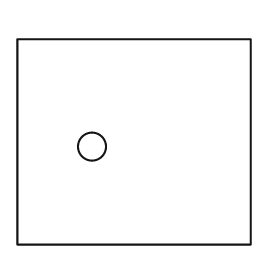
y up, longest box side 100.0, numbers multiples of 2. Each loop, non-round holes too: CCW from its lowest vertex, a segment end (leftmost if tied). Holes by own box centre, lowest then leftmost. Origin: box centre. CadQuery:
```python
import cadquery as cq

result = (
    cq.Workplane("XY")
    .moveTo(-50.0, -44.0)
    .lineTo(50.0, -44.0)
    .lineTo(50.0, 44.0)
    .lineTo(-50.0, 44.0)
    .close()
    .moveTo(-18.0, -2.0)
    .circle(6.0)
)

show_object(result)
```